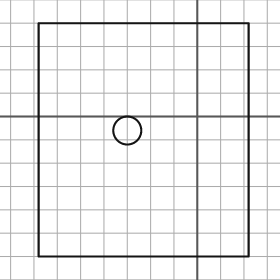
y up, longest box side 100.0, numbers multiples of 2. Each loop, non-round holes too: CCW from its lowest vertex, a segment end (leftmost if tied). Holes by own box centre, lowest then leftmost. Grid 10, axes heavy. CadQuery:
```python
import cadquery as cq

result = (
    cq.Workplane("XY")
    .moveTo(-68.0, -60.0)
    .lineTo(22.0, -60.0)
    .lineTo(22.0, 40.0)
    .lineTo(-68.0, 40.0)
    .close()
    .moveTo(-30.0, -6.0)
    .circle(6.0)
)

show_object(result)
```